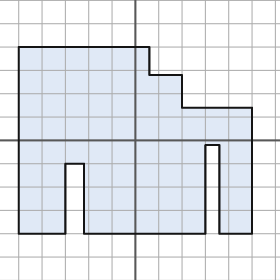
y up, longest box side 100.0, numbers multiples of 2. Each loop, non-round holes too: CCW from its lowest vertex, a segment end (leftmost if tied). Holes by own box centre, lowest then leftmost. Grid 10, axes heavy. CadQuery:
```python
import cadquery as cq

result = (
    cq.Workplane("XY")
    .moveTo(-50.0, -40.0)
    .lineTo(-30.0, -40.0)
    .lineTo(-30.0, -10.0)
    .lineTo(-22.0, -10.0)
    .lineTo(-22.0, -40.0)
    .lineTo(30.0, -40.0)
    .lineTo(30.0, -2.0)
    .lineTo(36.0, -2.0)
    .lineTo(36.0, -40.0)
    .lineTo(50.0, -40.0)
    .lineTo(50.0, 14.0)
    .lineTo(20.0, 14.0)
    .lineTo(20.0, 28.0)
    .lineTo(6.0, 28.0)
    .lineTo(6.0, 40.0)
    .lineTo(-50.0, 40.0)
    .close()
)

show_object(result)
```